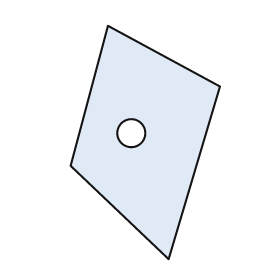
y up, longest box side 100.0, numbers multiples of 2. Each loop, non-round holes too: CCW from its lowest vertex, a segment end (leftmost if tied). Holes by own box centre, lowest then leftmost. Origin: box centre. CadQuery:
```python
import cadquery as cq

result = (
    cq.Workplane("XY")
    .moveTo(10.0, -50.0)
    .lineTo(32.0, 24.0)
    .lineTo(-16.0, 50.0)
    .lineTo(-32.0, -10.0)
    .close()
    .moveTo(-6.0, 4.0)
    .circle(6.0)
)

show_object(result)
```